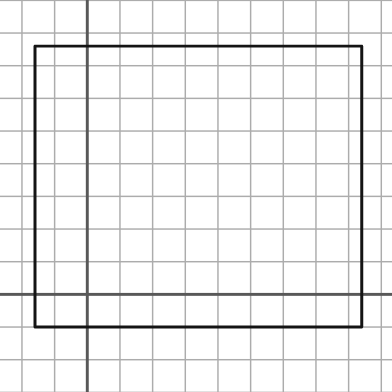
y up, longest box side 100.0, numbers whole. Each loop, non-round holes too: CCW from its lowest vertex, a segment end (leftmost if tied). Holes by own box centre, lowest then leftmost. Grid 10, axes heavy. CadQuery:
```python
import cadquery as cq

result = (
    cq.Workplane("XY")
    .moveTo(-16.0, -10.0)
    .lineTo(84.0, -10.0)
    .lineTo(84.0, 76.0)
    .lineTo(-16.0, 76.0)
    .close()
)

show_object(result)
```